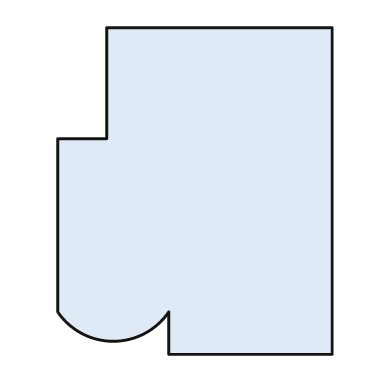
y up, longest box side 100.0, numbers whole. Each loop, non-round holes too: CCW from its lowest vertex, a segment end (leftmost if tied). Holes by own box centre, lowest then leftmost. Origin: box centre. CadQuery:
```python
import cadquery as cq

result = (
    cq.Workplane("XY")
    .moveTo(-8.0, -50.0)
    .lineTo(42.0, -50.0)
    .lineTo(42.0, 50.0)
    .lineTo(-27.0, 50.0)
    .lineTo(-27.0, 16.0)
    .lineTo(-42.0, 16.0)
    .lineTo(-42.0, -37.0)
    .threePointArc((-25.0, -46.0), (-8.0, -37.0))
    .close()
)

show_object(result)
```